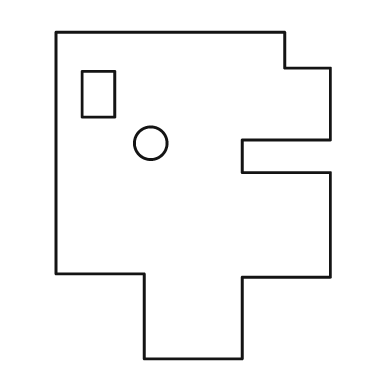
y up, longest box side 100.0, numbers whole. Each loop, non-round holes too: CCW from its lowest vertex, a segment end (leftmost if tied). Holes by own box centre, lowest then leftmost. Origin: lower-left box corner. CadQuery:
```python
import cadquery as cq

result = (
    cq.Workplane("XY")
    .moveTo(27.0, 0.0)
    .lineTo(57.0, 0.0)
    .lineTo(57.0, 25.0)
    .lineTo(84.0, 25.0)
    .lineTo(84.0, 57.0)
    .lineTo(57.0, 57.0)
    .lineTo(57.0, 67.0)
    .lineTo(84.0, 67.0)
    .lineTo(84.0, 89.0)
    .lineTo(70.0, 89.0)
    .lineTo(70.0, 100.0)
    .lineTo(0.0, 100.0)
    .lineTo(0.0, 26.0)
    .lineTo(27.0, 26.0)
    .close()
    .moveTo(29.0, 66.0)
    .circle(5.0)
    .moveTo(8.0, 74.0)
    .lineTo(18.0, 74.0)
    .lineTo(18.0, 88.0)
    .lineTo(8.0, 88.0)
    .close()
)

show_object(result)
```